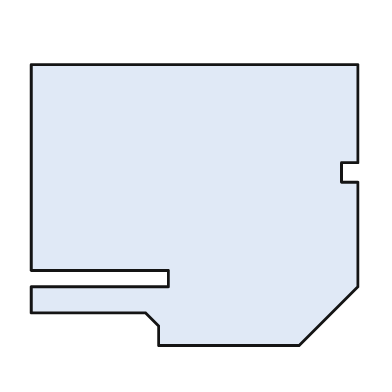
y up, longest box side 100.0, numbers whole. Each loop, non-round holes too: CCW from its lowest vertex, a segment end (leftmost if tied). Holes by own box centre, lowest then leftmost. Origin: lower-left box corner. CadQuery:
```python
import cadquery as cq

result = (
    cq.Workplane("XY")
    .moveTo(39.0, 0.0)
    .lineTo(82.0, 0.0)
    .lineTo(100.0, 18.0)
    .lineTo(100.0, 50.0)
    .lineTo(95.0, 50.0)
    .lineTo(95.0, 56.0)
    .lineTo(100.0, 56.0)
    .lineTo(100.0, 86.0)
    .lineTo(0.0, 86.0)
    .lineTo(0.0, 23.0)
    .lineTo(42.0, 23.0)
    .lineTo(42.0, 18.0)
    .lineTo(0.0, 18.0)
    .lineTo(0.0, 10.0)
    .lineTo(35.0, 10.0)
    .lineTo(39.0, 6.0)
    .close()
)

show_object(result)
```